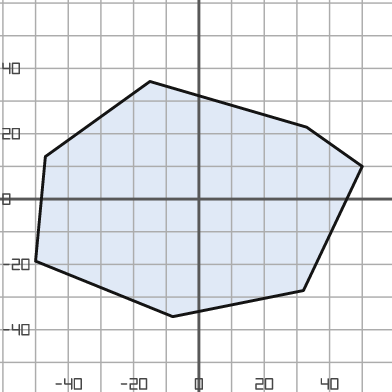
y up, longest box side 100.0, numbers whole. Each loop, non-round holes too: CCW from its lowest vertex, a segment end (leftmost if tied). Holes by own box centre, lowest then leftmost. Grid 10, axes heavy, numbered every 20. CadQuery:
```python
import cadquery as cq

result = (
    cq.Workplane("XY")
    .moveTo(-8.0, -36.0)
    .lineTo(32.0, -28.0)
    .lineTo(50.0, 10.0)
    .lineTo(33.0, 22.0)
    .lineTo(-15.0, 36.0)
    .lineTo(-47.0, 13.0)
    .lineTo(-50.0, -19.0)
    .close()
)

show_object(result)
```